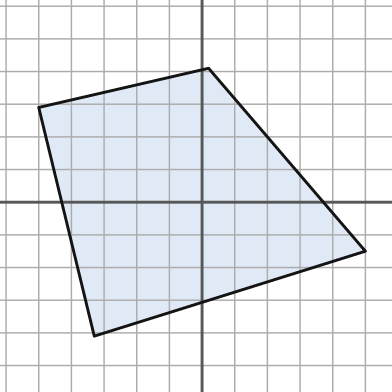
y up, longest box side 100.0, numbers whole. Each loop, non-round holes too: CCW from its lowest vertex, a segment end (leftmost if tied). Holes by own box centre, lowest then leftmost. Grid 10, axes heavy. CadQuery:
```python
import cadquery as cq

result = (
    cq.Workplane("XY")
    .moveTo(-33.0, -41.0)
    .lineTo(50.0, -15.0)
    .lineTo(2.0, 41.0)
    .lineTo(-50.0, 29.0)
    .close()
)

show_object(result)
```